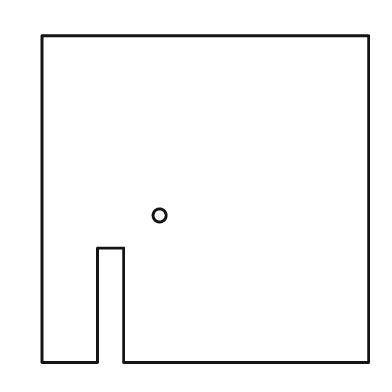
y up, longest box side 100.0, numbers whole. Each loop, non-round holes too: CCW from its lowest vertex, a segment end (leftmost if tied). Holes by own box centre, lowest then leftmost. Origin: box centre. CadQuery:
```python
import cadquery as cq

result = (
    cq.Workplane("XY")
    .moveTo(-50.0, -50.0)
    .lineTo(-33.0, -50.0)
    .lineTo(-33.0, -15.0)
    .lineTo(-25.0, -15.0)
    .lineTo(-25.0, -50.0)
    .lineTo(50.0, -50.0)
    .lineTo(50.0, 50.0)
    .lineTo(-50.0, 50.0)
    .close()
    .moveTo(-14.0, -5.0)
    .circle(2.0)
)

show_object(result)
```